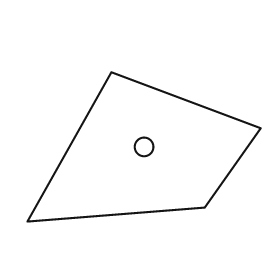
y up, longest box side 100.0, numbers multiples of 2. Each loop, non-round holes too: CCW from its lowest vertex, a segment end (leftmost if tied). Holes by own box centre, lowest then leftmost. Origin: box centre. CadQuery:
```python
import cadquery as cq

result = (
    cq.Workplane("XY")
    .moveTo(-50.0, -32.0)
    .lineTo(26.0, -26.0)
    .lineTo(50.0, 8.0)
    .lineTo(-14.0, 32.0)
    .close()
    .moveTo(0.0, 0.0)
    .circle(4.0)
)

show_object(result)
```